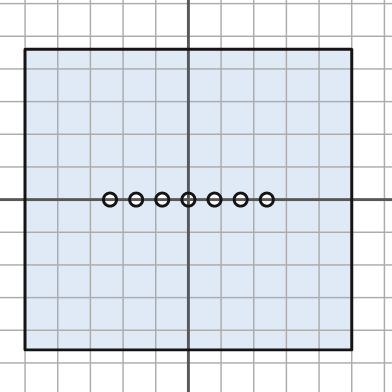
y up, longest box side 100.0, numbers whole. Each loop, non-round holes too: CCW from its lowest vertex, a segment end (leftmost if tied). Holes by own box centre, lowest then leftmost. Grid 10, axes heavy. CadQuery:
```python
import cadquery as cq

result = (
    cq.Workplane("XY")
    .moveTo(-50.0, -46.0)
    .lineTo(50.0, -46.0)
    .lineTo(50.0, 46.0)
    .lineTo(-50.0, 46.0)
    .close()
    .moveTo(-24.0, 0.0)
    .circle(2.0)
    .moveTo(-16.0, 0.0)
    .circle(2.0)
    .moveTo(-8.0, 0.0)
    .circle(2.0)
    .moveTo(0.0, 0.0)
    .circle(2.0)
    .moveTo(8.0, 0.0)
    .circle(2.0)
    .moveTo(16.0, 0.0)
    .circle(2.0)
    .moveTo(24.0, 0.0)
    .circle(2.0)
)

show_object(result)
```